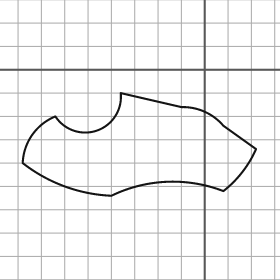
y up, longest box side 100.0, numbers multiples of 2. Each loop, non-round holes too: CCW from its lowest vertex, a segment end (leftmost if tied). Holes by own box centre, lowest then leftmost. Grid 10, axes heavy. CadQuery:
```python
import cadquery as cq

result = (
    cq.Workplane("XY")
    .moveTo(-40.0, -54.0)
    .threePointArc((-16.0, -48.0), (8.0, -52.0))
    .threePointArc((16.0, -44.0), (22.0, -34.0))
    .lineTo(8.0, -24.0)
    .threePointArc((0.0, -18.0), (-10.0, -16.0))
    .lineTo(-36.0, -10.0)
    .threePointArc((-46.0, -26.0), (-64.0, -20.0))
    .threePointArc((-74.0, -28.0), (-78.0, -40.0))
    .threePointArc((-60.0, -50.0), (-40.0, -54.0))
    .close()
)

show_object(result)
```